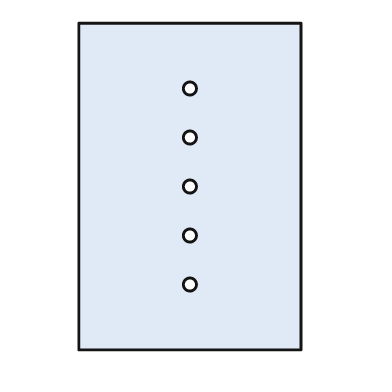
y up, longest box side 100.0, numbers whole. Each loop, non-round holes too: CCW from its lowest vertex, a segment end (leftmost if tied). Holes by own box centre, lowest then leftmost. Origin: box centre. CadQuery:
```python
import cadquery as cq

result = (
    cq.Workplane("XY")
    .moveTo(-34.0, -50.0)
    .lineTo(34.0, -50.0)
    .lineTo(34.0, 50.0)
    .lineTo(-34.0, 50.0)
    .close()
    .moveTo(0.0, -30.0)
    .circle(2.0)
    .moveTo(0.0, -15.0)
    .circle(2.0)
    .moveTo(0.0, 0.0)
    .circle(2.0)
    .moveTo(0.0, 15.0)
    .circle(2.0)
    .moveTo(0.0, 30.0)
    .circle(2.0)
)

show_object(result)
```